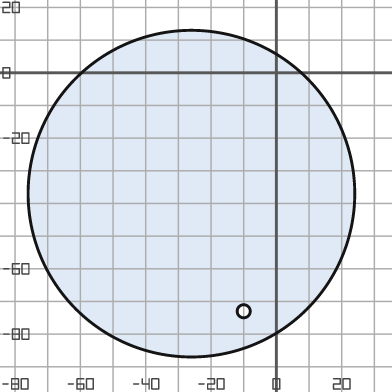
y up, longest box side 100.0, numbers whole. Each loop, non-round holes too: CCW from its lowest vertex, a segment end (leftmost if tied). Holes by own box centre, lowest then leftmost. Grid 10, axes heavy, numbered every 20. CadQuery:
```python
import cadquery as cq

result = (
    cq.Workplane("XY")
    .moveTo(-26.0, -37.0)
    .circle(50.0)
    .moveTo(-10.0, -73.0)
    .circle(2.0)
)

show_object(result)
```